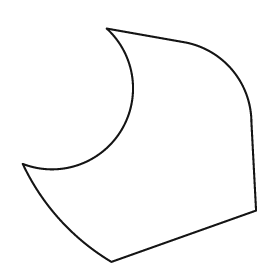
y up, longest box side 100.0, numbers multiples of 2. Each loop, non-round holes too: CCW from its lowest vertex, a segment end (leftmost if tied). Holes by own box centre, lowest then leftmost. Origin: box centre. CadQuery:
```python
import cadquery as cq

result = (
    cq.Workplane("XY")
    .moveTo(-12.0, -50.0)
    .lineTo(50.0, -28.0)
    .lineTo(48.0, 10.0)
    .threePointArc((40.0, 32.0), (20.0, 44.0))
    .lineTo(-14.0, 50.0)
    .threePointArc((-8.0, 6.0), (-50.0, -8.0))
    .threePointArc((-34.0, -32.0), (-12.0, -50.0))
    .close()
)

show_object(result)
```